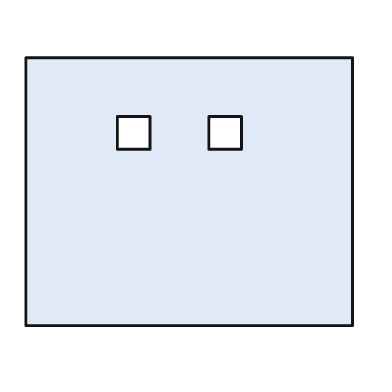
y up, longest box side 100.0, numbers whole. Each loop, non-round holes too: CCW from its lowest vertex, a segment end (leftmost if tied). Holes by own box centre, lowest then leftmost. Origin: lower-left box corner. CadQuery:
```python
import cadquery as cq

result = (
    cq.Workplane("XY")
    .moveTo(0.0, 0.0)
    .lineTo(100.0, 0.0)
    .lineTo(100.0, 82.0)
    .lineTo(0.0, 82.0)
    .close()
    .moveTo(28.0, 54.0)
    .lineTo(38.0, 54.0)
    .lineTo(38.0, 64.0)
    .lineTo(28.0, 64.0)
    .close()
    .moveTo(56.0, 54.0)
    .lineTo(66.0, 54.0)
    .lineTo(66.0, 64.0)
    .lineTo(56.0, 64.0)
    .close()
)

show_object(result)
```